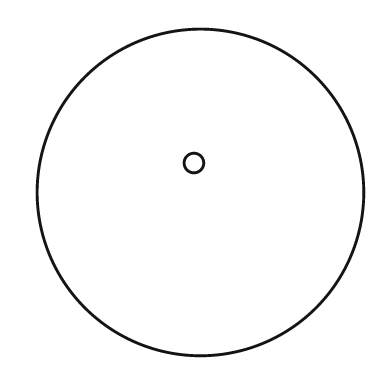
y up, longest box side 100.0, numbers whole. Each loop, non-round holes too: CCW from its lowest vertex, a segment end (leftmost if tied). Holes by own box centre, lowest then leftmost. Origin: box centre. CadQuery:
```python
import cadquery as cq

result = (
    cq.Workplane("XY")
    .moveTo(0.0, 0.0)
    .circle(50.0)
    .moveTo(-2.0, 9.0)
    .circle(3.0)
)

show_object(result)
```